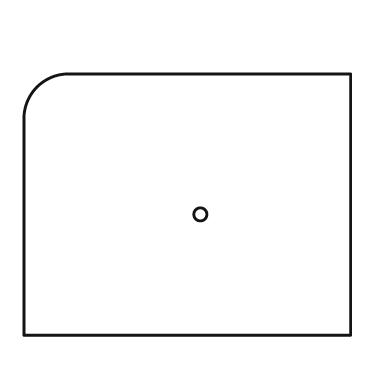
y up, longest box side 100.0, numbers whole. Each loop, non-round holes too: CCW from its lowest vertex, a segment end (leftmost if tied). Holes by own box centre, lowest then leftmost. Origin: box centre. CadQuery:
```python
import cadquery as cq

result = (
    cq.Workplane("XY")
    .moveTo(-50.0, -40.0)
    .lineTo(50.0, -40.0)
    .lineTo(50.0, 40.0)
    .lineTo(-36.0, 40.0)
    .threePointArc((-46.0, 36.0), (-50.0, 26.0))
    .close()
    .moveTo(4.0, -3.0)
    .circle(2.0)
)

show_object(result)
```